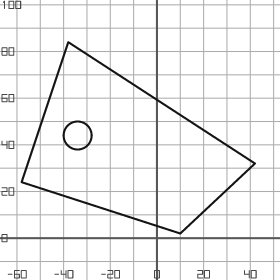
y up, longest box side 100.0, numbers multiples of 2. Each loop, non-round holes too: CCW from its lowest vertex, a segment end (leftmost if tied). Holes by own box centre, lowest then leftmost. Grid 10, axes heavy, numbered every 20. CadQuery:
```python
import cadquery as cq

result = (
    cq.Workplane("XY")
    .moveTo(10.0, 2.0)
    .lineTo(42.0, 32.0)
    .lineTo(-38.0, 84.0)
    .lineTo(-58.0, 24.0)
    .close()
    .moveTo(-34.0, 44.0)
    .circle(6.0)
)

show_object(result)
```